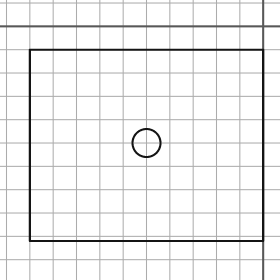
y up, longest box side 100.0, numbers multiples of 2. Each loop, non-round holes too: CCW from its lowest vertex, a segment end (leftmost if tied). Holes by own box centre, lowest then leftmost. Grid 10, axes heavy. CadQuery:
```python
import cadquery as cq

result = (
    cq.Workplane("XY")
    .moveTo(-100.0, -92.0)
    .lineTo(0.0, -92.0)
    .lineTo(0.0, -10.0)
    .lineTo(-100.0, -10.0)
    .close()
    .moveTo(-50.0, -50.0)
    .circle(6.0)
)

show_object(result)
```